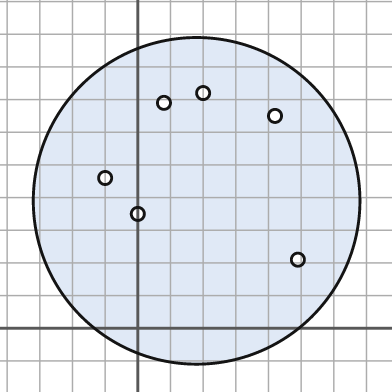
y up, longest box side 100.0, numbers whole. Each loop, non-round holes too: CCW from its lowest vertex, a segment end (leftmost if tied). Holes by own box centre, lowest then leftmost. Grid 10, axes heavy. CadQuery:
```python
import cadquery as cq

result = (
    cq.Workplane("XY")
    .moveTo(18.0, 39.0)
    .circle(50.0)
    .moveTo(49.0, 21.0)
    .circle(2.0)
    .moveTo(0.0, 35.0)
    .circle(2.0)
    .moveTo(-10.0, 46.0)
    .circle(2.0)
    .moveTo(42.0, 65.0)
    .circle(2.0)
    .moveTo(8.0, 69.0)
    .circle(2.0)
    .moveTo(20.0, 72.0)
    .circle(2.0)
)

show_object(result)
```